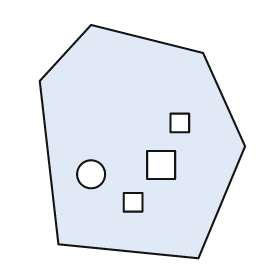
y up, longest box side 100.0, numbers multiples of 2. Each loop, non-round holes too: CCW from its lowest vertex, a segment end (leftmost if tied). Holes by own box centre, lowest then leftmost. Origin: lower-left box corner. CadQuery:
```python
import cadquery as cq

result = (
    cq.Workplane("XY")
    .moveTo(68.0, 0.0)
    .lineTo(88.0, 48.0)
    .lineTo(70.0, 88.0)
    .lineTo(22.0, 100.0)
    .lineTo(0.0, 76.0)
    .lineTo(8.0, 6.0)
    .close()
    .moveTo(36.0, 20.0)
    .lineTo(44.0, 20.0)
    .lineTo(44.0, 28.0)
    .lineTo(36.0, 28.0)
    .close()
    .moveTo(22.0, 36.0)
    .circle(6.0)
    .moveTo(46.0, 34.0)
    .lineTo(58.0, 34.0)
    .lineTo(58.0, 46.0)
    .lineTo(46.0, 46.0)
    .close()
    .moveTo(56.0, 54.0)
    .lineTo(64.0, 54.0)
    .lineTo(64.0, 62.0)
    .lineTo(56.0, 62.0)
    .close()
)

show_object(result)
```